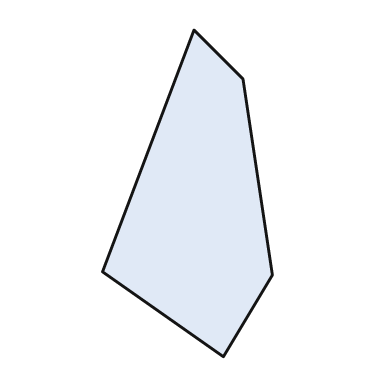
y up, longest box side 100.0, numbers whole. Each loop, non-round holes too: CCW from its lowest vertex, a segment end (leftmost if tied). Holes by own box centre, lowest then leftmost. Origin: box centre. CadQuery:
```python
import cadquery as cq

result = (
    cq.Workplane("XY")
    .moveTo(11.0, -50.0)
    .lineTo(26.0, -25.0)
    .lineTo(17.0, 35.0)
    .lineTo(2.0, 50.0)
    .lineTo(-26.0, -24.0)
    .close()
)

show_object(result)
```